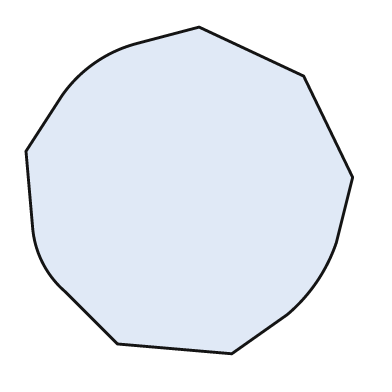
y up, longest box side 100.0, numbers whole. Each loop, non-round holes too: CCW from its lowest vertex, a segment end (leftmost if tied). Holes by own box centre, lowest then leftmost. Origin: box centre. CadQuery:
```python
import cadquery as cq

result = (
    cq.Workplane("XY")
    .moveTo(13.0, -50.0)
    .lineTo(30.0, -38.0)
    .threePointArc((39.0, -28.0), (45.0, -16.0))
    .lineTo(50.0, 4.0)
    .lineTo(35.0, 35.0)
    .lineTo(3.0, 50.0)
    .lineTo(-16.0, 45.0)
    .threePointArc((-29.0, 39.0), (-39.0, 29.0))
    .lineTo(-50.0, 12.0)
    .lineTo(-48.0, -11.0)
    .threePointArc((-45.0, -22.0), (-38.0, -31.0))
    .lineTo(-22.0, -47.0)
    .close()
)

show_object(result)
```